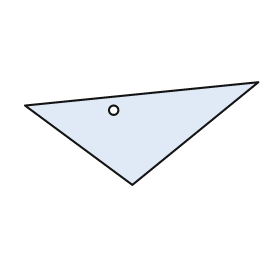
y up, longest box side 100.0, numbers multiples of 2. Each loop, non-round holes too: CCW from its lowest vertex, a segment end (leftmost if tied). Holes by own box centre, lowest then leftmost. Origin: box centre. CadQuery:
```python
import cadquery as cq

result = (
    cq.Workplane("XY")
    .moveTo(-4.0, -22.0)
    .lineTo(50.0, 22.0)
    .lineTo(-50.0, 12.0)
    .close()
    .moveTo(-12.0, 10.0)
    .circle(2.0)
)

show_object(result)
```